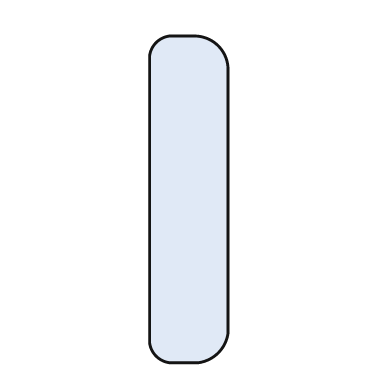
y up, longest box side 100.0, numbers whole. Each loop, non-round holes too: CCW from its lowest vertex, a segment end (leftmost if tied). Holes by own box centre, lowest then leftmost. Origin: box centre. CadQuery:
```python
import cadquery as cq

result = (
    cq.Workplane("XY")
    .moveTo(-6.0, -50.0)
    .lineTo(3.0, -50.0)
    .threePointArc((9.0, -47.0), (12.0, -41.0))
    .lineTo(12.0, 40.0)
    .threePointArc((9.0, 47.0), (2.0, 50.0))
    .lineTo(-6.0, 50.0)
    .threePointArc((-10.0, 48.0), (-12.0, 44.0))
    .lineTo(-12.0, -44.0)
    .threePointArc((-10.0, -48.0), (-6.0, -50.0))
    .close()
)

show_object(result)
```